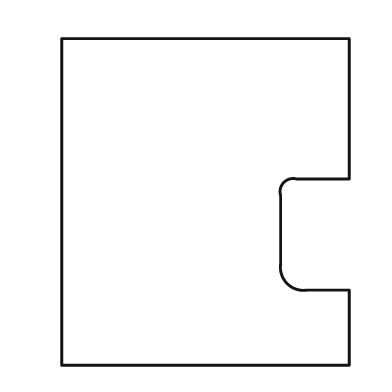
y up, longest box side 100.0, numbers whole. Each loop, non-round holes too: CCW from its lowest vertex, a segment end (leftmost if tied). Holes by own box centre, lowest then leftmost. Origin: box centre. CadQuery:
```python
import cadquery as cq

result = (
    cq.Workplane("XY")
    .moveTo(-44.0, -50.0)
    .lineTo(44.0, -50.0)
    .lineTo(44.0, -27.0)
    .lineTo(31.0, -27.0)
    .threePointArc((25.0, -25.0), (23.0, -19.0))
    .lineTo(23.0, 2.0)
    .threePointArc((24.0, 6.0), (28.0, 7.0))
    .lineTo(44.0, 7.0)
    .lineTo(44.0, 50.0)
    .lineTo(-44.0, 50.0)
    .close()
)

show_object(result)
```